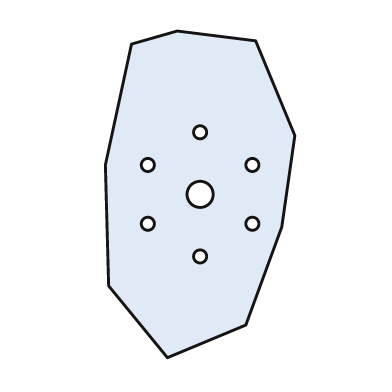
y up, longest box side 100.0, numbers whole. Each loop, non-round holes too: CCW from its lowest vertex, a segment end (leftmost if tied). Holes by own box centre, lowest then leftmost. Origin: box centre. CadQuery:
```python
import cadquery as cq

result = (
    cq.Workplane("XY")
    .moveTo(-10.0, -50.0)
    .lineTo(14.0, -40.0)
    .lineTo(25.0, -10.0)
    .lineTo(29.0, 18.0)
    .lineTo(17.0, 47.0)
    .lineTo(-7.0, 50.0)
    .lineTo(-21.0, 46.0)
    .lineTo(-29.0, 9.0)
    .lineTo(-28.0, -28.0)
    .close()
    .moveTo(0.0, -19.0)
    .circle(2.0)
    .moveTo(-16.0, -9.0)
    .circle(2.0)
    .moveTo(16.0, -9.0)
    .circle(2.0)
    .moveTo(0.0, 0.0)
    .circle(4.0)
    .moveTo(-16.0, 9.0)
    .circle(2.0)
    .moveTo(16.0, 9.0)
    .circle(2.0)
    .moveTo(0.0, 19.0)
    .circle(2.0)
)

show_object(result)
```